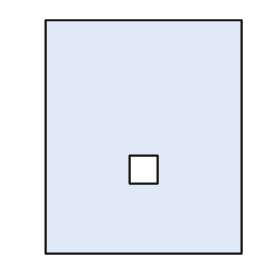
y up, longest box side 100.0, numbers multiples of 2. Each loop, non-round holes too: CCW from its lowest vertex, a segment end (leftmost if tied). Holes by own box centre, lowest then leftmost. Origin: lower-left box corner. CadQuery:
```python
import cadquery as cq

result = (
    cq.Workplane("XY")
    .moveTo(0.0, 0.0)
    .lineTo(84.0, 0.0)
    .lineTo(84.0, 100.0)
    .lineTo(0.0, 100.0)
    .close()
    .moveTo(36.0, 30.0)
    .lineTo(48.0, 30.0)
    .lineTo(48.0, 42.0)
    .lineTo(36.0, 42.0)
    .close()
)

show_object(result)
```